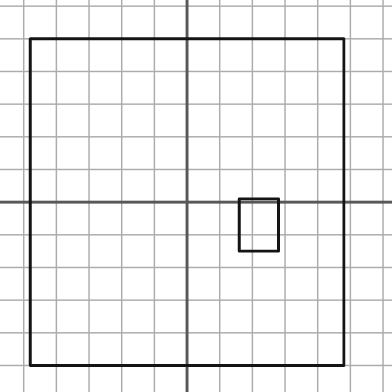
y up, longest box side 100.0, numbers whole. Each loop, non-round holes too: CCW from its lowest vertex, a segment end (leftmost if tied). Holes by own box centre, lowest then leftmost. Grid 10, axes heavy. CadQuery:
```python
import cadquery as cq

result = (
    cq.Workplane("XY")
    .moveTo(-48.0, -50.0)
    .lineTo(48.0, -50.0)
    .lineTo(48.0, 50.0)
    .lineTo(-48.0, 50.0)
    .close()
    .moveTo(16.0, -15.0)
    .lineTo(28.0, -15.0)
    .lineTo(28.0, 1.0)
    .lineTo(16.0, 1.0)
    .close()
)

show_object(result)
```